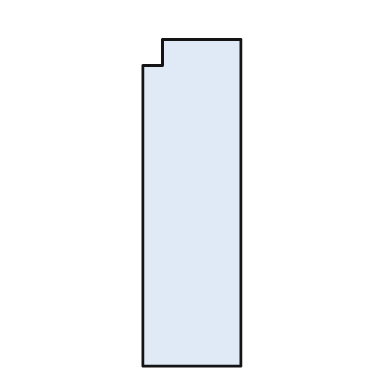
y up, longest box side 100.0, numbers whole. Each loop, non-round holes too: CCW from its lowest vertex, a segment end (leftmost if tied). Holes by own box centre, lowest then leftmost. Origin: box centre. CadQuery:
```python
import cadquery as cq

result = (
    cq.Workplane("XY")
    .moveTo(-15.0, -50.0)
    .lineTo(15.0, -50.0)
    .lineTo(15.0, 50.0)
    .lineTo(-9.0, 50.0)
    .lineTo(-9.0, 42.0)
    .lineTo(-15.0, 42.0)
    .close()
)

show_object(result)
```